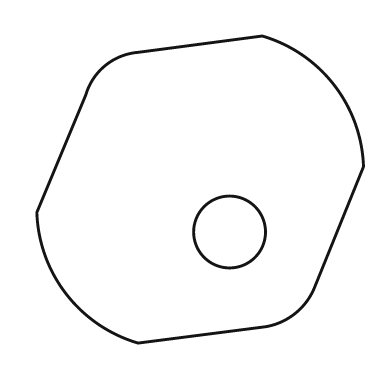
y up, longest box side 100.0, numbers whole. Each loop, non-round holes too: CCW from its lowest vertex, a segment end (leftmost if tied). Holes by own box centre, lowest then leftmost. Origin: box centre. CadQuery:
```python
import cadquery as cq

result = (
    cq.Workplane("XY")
    .moveTo(-19.0, -47.0)
    .lineTo(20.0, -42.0)
    .threePointArc((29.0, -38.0), (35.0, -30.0))
    .lineTo(50.0, 7.0)
    .threePointArc((41.0, 32.0), (19.0, 47.0))
    .lineTo(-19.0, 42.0)
    .threePointArc((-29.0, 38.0), (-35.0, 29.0))
    .lineTo(-50.0, -7.0)
    .threePointArc((-41.0, -32.0), (-19.0, -47.0))
    .close()
    .moveTo(9.0, -13.0)
    .circle(11.0)
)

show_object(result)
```